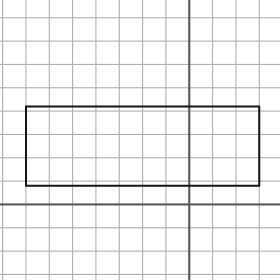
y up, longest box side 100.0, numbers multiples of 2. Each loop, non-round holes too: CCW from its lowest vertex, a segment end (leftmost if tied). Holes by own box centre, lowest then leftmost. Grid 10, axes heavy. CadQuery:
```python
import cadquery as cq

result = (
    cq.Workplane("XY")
    .moveTo(-70.0, 8.0)
    .lineTo(30.0, 8.0)
    .lineTo(30.0, 42.0)
    .lineTo(-70.0, 42.0)
    .close()
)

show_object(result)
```